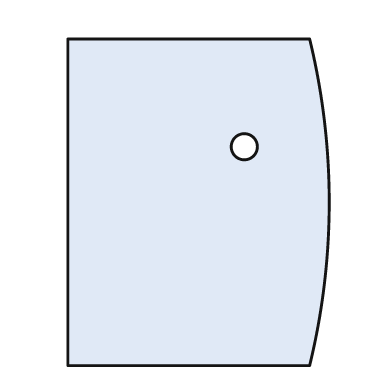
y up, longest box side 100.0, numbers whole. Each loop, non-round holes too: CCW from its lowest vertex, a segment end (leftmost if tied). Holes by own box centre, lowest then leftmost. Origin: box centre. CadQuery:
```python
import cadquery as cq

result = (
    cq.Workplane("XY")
    .moveTo(-40.0, -50.0)
    .lineTo(34.0, -50.0)
    .threePointArc((40.0, 0.0), (34.0, 50.0))
    .lineTo(-40.0, 50.0)
    .close()
    .moveTo(14.0, 17.0)
    .circle(4.0)
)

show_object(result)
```